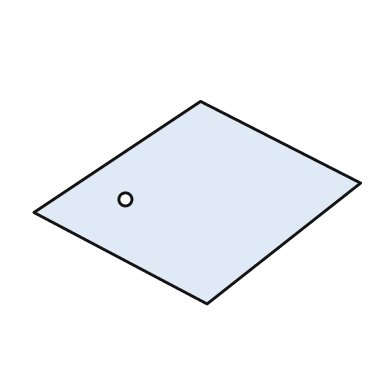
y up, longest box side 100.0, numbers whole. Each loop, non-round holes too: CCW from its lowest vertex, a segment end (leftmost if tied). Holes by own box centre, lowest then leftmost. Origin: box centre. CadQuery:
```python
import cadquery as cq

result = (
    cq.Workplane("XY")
    .moveTo(3.0, -31.0)
    .lineTo(50.0, 6.0)
    .lineTo(1.0, 31.0)
    .lineTo(-50.0, -3.0)
    .close()
    .moveTo(-22.0, 1.0)
    .circle(2.0)
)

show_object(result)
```